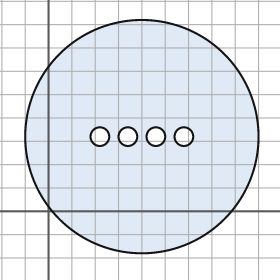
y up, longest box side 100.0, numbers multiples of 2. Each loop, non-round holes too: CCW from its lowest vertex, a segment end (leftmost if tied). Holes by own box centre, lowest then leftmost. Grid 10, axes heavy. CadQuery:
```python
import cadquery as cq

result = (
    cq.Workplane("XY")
    .moveTo(40.0, 32.0)
    .circle(50.0)
    .moveTo(22.0, 32.0)
    .circle(4.0)
    .moveTo(34.0, 32.0)
    .circle(4.0)
    .moveTo(46.0, 32.0)
    .circle(4.0)
    .moveTo(58.0, 32.0)
    .circle(4.0)
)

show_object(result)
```